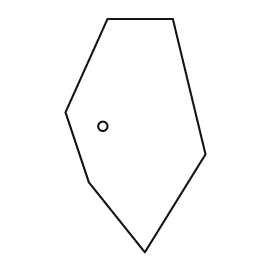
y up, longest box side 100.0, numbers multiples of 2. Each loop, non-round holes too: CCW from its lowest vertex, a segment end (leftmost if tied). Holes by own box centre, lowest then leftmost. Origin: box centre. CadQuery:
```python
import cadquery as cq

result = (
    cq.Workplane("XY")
    .moveTo(4.0, -50.0)
    .lineTo(30.0, -8.0)
    .lineTo(16.0, 50.0)
    .lineTo(-12.0, 50.0)
    .lineTo(-30.0, 10.0)
    .lineTo(-20.0, -20.0)
    .close()
    .moveTo(-14.0, 4.0)
    .circle(2.0)
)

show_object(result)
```